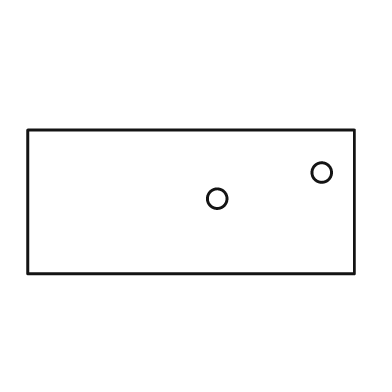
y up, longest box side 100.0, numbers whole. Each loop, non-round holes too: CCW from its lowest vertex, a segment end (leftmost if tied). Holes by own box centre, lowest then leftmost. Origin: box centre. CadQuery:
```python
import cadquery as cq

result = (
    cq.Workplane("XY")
    .moveTo(-50.0, -22.0)
    .lineTo(50.0, -22.0)
    .lineTo(50.0, 22.0)
    .lineTo(-50.0, 22.0)
    .close()
    .moveTo(8.0, 1.0)
    .circle(3.0)
    .moveTo(40.0, 9.0)
    .circle(3.0)
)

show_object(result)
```